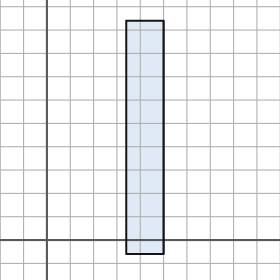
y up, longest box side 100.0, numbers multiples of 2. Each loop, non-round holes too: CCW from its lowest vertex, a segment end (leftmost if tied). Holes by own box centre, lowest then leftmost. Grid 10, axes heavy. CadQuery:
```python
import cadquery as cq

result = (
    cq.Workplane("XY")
    .moveTo(34.0, -6.0)
    .lineTo(50.0, -6.0)
    .lineTo(50.0, 94.0)
    .lineTo(34.0, 94.0)
    .close()
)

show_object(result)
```